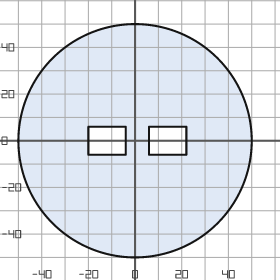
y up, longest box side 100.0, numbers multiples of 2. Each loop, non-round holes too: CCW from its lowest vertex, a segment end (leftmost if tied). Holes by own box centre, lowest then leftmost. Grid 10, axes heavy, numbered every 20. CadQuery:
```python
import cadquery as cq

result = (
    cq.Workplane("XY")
    .moveTo(0.0, 0.0)
    .circle(50.0)
    .moveTo(-20.0, -6.0)
    .lineTo(-4.0, -6.0)
    .lineTo(-4.0, 6.0)
    .lineTo(-20.0, 6.0)
    .close()
    .moveTo(6.0, -6.0)
    .lineTo(22.0, -6.0)
    .lineTo(22.0, 6.0)
    .lineTo(6.0, 6.0)
    .close()
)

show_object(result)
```